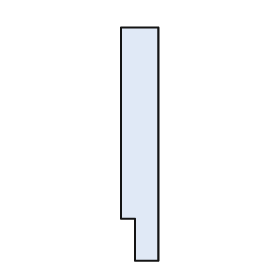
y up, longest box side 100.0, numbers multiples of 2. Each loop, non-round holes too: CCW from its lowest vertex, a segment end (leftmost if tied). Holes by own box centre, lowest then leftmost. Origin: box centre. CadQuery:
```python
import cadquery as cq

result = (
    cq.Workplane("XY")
    .moveTo(-2.0, -50.0)
    .lineTo(8.0, -50.0)
    .lineTo(8.0, 50.0)
    .lineTo(-8.0, 50.0)
    .lineTo(-8.0, -32.0)
    .lineTo(-2.0, -32.0)
    .close()
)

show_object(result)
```